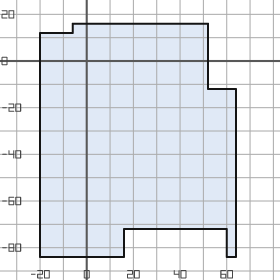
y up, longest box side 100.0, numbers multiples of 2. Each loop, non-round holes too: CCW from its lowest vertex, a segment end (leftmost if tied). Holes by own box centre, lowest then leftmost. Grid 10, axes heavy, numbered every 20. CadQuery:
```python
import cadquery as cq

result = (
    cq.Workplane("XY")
    .moveTo(-20.0, -84.0)
    .lineTo(16.0, -84.0)
    .lineTo(16.0, -72.0)
    .lineTo(60.0, -72.0)
    .lineTo(60.0, -84.0)
    .lineTo(64.0, -84.0)
    .lineTo(64.0, -12.0)
    .lineTo(52.0, -12.0)
    .lineTo(52.0, 16.0)
    .lineTo(-6.0, 16.0)
    .lineTo(-6.0, 12.0)
    .lineTo(-20.0, 12.0)
    .close()
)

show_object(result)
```